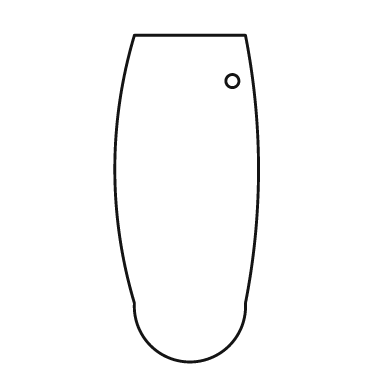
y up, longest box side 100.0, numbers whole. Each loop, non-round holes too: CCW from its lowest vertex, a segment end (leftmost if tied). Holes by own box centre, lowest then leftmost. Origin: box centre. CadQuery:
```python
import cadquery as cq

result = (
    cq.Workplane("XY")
    .moveTo(-16.0, -32.0)
    .threePointArc((1.0, -50.0), (18.0, -32.0))
    .threePointArc((22.0, 9.0), (18.0, 50.0))
    .lineTo(-16.0, 50.0)
    .threePointArc((-22.0, 9.0), (-16.0, -32.0))
    .close()
    .moveTo(14.0, 36.0)
    .circle(2.0)
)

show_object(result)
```